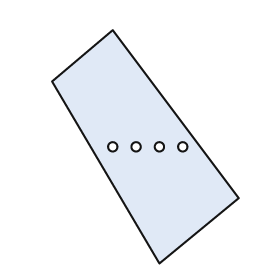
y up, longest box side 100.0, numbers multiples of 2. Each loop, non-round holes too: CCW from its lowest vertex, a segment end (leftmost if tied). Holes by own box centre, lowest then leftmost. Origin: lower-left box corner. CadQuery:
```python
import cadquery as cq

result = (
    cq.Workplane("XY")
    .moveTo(46.0, 0.0)
    .lineTo(80.0, 28.0)
    .lineTo(26.0, 100.0)
    .lineTo(0.0, 78.0)
    .close()
    .moveTo(26.0, 50.0)
    .circle(2.0)
    .moveTo(36.0, 50.0)
    .circle(2.0)
    .moveTo(46.0, 50.0)
    .circle(2.0)
    .moveTo(56.0, 50.0)
    .circle(2.0)
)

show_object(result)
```